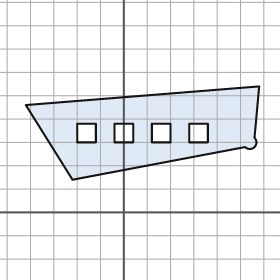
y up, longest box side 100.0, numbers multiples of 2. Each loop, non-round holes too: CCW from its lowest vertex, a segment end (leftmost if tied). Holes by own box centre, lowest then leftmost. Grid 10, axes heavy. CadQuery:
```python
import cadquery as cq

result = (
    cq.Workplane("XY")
    .moveTo(-22.0, 14.0)
    .lineTo(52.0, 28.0)
    .threePointArc((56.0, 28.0), (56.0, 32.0))
    .lineTo(58.0, 54.0)
    .lineTo(-42.0, 46.0)
    .close()
    .moveTo(-20.0, 30.0)
    .lineTo(-12.0, 30.0)
    .lineTo(-12.0, 38.0)
    .lineTo(-20.0, 38.0)
    .close()
    .moveTo(-4.0, 30.0)
    .lineTo(4.0, 30.0)
    .lineTo(4.0, 38.0)
    .lineTo(-4.0, 38.0)
    .close()
    .moveTo(12.0, 30.0)
    .lineTo(20.0, 30.0)
    .lineTo(20.0, 38.0)
    .lineTo(12.0, 38.0)
    .close()
    .moveTo(28.0, 30.0)
    .lineTo(36.0, 30.0)
    .lineTo(36.0, 38.0)
    .lineTo(28.0, 38.0)
    .close()
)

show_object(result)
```